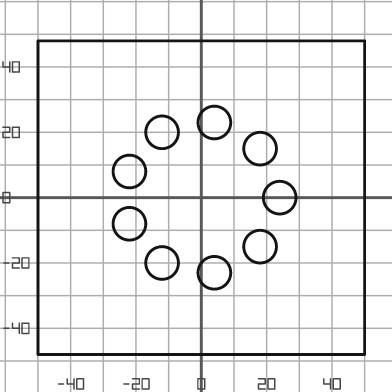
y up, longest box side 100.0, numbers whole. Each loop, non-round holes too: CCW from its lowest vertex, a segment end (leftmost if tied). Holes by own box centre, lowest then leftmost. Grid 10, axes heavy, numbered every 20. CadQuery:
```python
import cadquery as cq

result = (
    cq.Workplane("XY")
    .moveTo(-50.0, -48.0)
    .lineTo(50.0, -48.0)
    .lineTo(50.0, 48.0)
    .lineTo(-50.0, 48.0)
    .close()
    .moveTo(4.0, -23.0)
    .circle(5.0)
    .moveTo(-12.0, -20.0)
    .circle(5.0)
    .moveTo(18.0, -15.0)
    .circle(5.0)
    .moveTo(-22.0, -8.0)
    .circle(5.0)
    .moveTo(24.0, 0.0)
    .circle(5.0)
    .moveTo(-22.0, 8.0)
    .circle(5.0)
    .moveTo(18.0, 15.0)
    .circle(5.0)
    .moveTo(-12.0, 20.0)
    .circle(5.0)
    .moveTo(4.0, 23.0)
    .circle(5.0)
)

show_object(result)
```